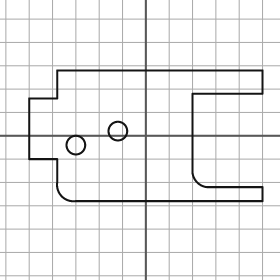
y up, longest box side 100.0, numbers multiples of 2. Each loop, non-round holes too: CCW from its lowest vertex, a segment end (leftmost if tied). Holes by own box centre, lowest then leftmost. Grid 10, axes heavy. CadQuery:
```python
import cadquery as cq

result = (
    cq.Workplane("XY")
    .moveTo(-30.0, -28.0)
    .lineTo(50.0, -28.0)
    .lineTo(50.0, -22.0)
    .lineTo(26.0, -22.0)
    .threePointArc((22.0, -20.0), (20.0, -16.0))
    .lineTo(20.0, 18.0)
    .lineTo(50.0, 18.0)
    .lineTo(50.0, 28.0)
    .lineTo(-38.0, 28.0)
    .lineTo(-38.0, 16.0)
    .lineTo(-50.0, 16.0)
    .lineTo(-50.0, -10.0)
    .lineTo(-38.0, -10.0)
    .lineTo(-38.0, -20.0)
    .threePointArc((-36.0, -26.0), (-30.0, -28.0))
    .close()
    .moveTo(-30.0, -4.0)
    .circle(4.0)
    .moveTo(-12.0, 2.0)
    .circle(4.0)
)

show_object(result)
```